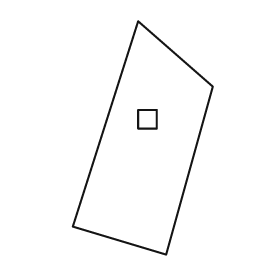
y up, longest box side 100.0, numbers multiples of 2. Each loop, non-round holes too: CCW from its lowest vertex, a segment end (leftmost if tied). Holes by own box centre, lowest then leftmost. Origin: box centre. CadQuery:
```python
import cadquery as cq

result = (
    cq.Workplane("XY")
    .moveTo(10.0, -50.0)
    .lineTo(30.0, 22.0)
    .lineTo(-2.0, 50.0)
    .lineTo(-30.0, -38.0)
    .close()
    .moveTo(-2.0, 4.0)
    .lineTo(6.0, 4.0)
    .lineTo(6.0, 12.0)
    .lineTo(-2.0, 12.0)
    .close()
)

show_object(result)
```